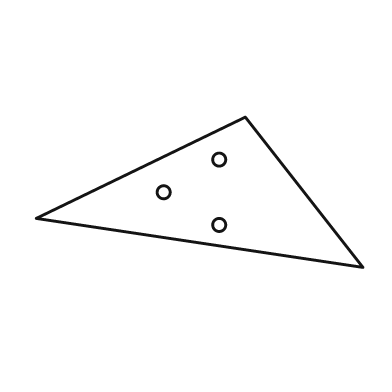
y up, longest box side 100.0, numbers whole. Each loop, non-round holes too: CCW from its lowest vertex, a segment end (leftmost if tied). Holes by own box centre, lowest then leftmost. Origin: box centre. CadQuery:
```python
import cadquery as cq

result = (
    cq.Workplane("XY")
    .moveTo(50.0, -23.0)
    .lineTo(14.0, 23.0)
    .lineTo(-50.0, -8.0)
    .close()
    .moveTo(6.0, -10.0)
    .circle(2.0)
    .moveTo(-11.0, 0.0)
    .circle(2.0)
    .moveTo(6.0, 10.0)
    .circle(2.0)
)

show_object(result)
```